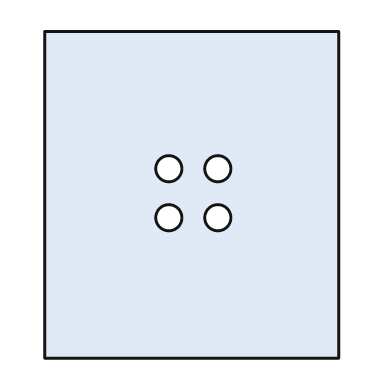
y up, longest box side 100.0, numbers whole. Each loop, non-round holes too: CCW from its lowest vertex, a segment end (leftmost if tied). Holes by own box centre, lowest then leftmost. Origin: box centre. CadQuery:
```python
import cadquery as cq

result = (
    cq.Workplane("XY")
    .moveTo(-45.0, -50.0)
    .lineTo(45.0, -50.0)
    .lineTo(45.0, 50.0)
    .lineTo(-45.0, 50.0)
    .close()
    .moveTo(-7.0, -7.0)
    .circle(4.0)
    .moveTo(8.0, -7.0)
    .circle(4.0)
    .moveTo(-7.0, 8.0)
    .circle(4.0)
    .moveTo(8.0, 8.0)
    .circle(4.0)
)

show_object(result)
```